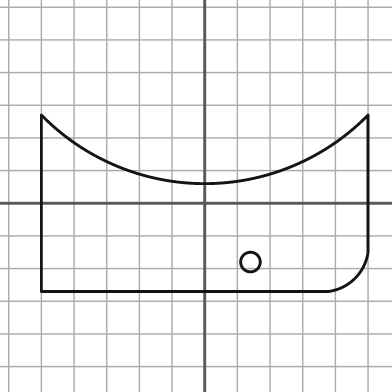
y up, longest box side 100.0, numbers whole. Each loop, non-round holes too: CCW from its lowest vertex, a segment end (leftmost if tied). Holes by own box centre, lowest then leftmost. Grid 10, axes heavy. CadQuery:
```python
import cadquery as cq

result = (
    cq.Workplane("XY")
    .moveTo(-50.0, -27.0)
    .lineTo(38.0, -27.0)
    .threePointArc((46.0, -23.0), (50.0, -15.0))
    .lineTo(50.0, 27.0)
    .threePointArc((0.0, 6.0), (-50.0, 27.0))
    .close()
    .moveTo(14.0, -18.0)
    .circle(3.0)
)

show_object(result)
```